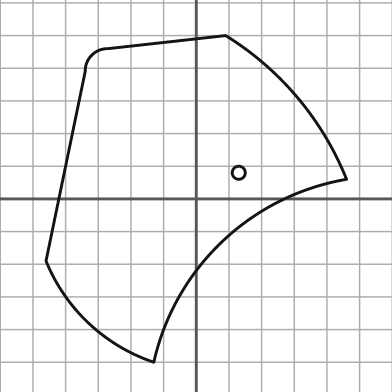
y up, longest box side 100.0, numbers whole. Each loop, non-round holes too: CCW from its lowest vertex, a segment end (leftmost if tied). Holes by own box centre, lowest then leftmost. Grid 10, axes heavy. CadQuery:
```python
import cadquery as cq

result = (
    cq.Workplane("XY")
    .moveTo(-13.0, -50.0)
    .threePointArc((8.0, -13.0), (46.0, 6.0))
    .threePointArc((31.0, 31.0), (9.0, 50.0))
    .lineTo(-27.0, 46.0)
    .threePointArc((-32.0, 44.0), (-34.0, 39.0))
    .lineTo(-46.0, -19.0)
    .threePointArc((-33.0, -38.0), (-13.0, -50.0))
    .close()
    .moveTo(13.0, 8.0)
    .circle(2.0)
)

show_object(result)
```